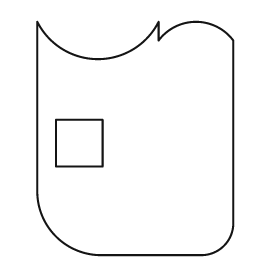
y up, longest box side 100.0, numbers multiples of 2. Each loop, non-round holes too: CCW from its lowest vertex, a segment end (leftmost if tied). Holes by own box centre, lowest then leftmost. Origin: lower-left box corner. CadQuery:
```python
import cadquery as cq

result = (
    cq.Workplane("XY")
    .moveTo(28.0, 0.0)
    .lineTo(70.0, 0.0)
    .threePointArc((80.0, 4.0), (84.0, 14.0))
    .lineTo(84.0, 92.0)
    .threePointArc((68.0, 100.0), (52.0, 92.0))
    .lineTo(52.0, 100.0)
    .threePointArc((26.0, 84.0), (0.0, 100.0))
    .lineTo(0.0, 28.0)
    .threePointArc((8.0, 8.0), (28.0, 0.0))
    .close()
    .moveTo(8.0, 38.0)
    .lineTo(28.0, 38.0)
    .lineTo(28.0, 58.0)
    .lineTo(8.0, 58.0)
    .close()
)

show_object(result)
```